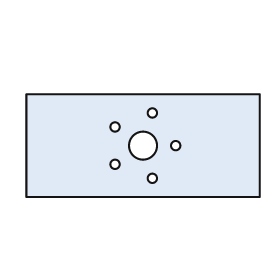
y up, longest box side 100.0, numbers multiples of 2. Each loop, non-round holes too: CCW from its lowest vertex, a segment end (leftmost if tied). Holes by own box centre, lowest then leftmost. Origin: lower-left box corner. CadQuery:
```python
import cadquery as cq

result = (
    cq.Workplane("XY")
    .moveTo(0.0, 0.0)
    .lineTo(100.0, 0.0)
    .lineTo(100.0, 44.0)
    .lineTo(0.0, 44.0)
    .close()
    .moveTo(54.0, 8.0)
    .circle(2.0)
    .moveTo(38.0, 14.0)
    .circle(2.0)
    .moveTo(50.0, 22.0)
    .circle(6.0)
    .moveTo(64.0, 22.0)
    .circle(2.0)
    .moveTo(38.0, 30.0)
    .circle(2.0)
    .moveTo(54.0, 36.0)
    .circle(2.0)
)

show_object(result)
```